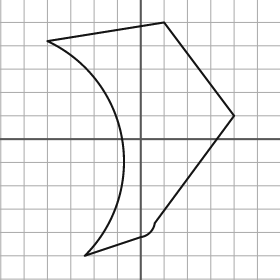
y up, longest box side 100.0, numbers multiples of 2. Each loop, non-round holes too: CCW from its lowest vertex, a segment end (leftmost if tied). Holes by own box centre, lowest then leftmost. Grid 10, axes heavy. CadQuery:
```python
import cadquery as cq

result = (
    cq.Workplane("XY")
    .moveTo(-24.0, -50.0)
    .lineTo(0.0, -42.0)
    .threePointArc((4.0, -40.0), (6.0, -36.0))
    .lineTo(40.0, 10.0)
    .lineTo(10.0, 50.0)
    .lineTo(-40.0, 42.0)
    .threePointArc((-8.0, 0.0), (-24.0, -50.0))
    .close()
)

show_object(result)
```